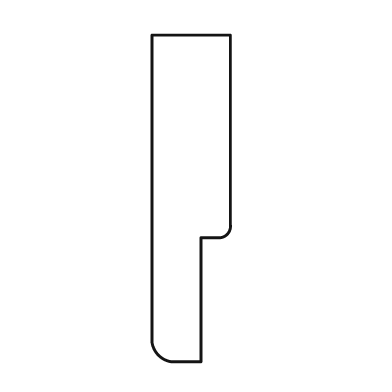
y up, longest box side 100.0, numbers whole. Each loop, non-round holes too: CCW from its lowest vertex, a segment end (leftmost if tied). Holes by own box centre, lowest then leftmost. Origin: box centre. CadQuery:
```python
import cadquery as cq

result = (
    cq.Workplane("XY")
    .moveTo(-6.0, -50.0)
    .lineTo(3.0, -50.0)
    .lineTo(3.0, -12.0)
    .lineTo(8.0, -12.0)
    .threePointArc((11.0, -11.0), (12.0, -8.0))
    .lineTo(12.0, 50.0)
    .lineTo(-12.0, 50.0)
    .lineTo(-12.0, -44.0)
    .threePointArc((-10.0, -48.0), (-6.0, -50.0))
    .close()
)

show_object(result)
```